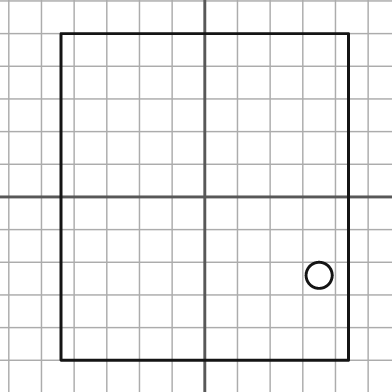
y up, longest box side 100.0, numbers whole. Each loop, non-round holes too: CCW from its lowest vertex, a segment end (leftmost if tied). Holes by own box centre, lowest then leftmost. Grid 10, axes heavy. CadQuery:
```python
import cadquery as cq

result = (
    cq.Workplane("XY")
    .moveTo(-44.0, -50.0)
    .lineTo(44.0, -50.0)
    .lineTo(44.0, 50.0)
    .lineTo(-44.0, 50.0)
    .close()
    .moveTo(35.0, -24.0)
    .circle(4.0)
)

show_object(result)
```